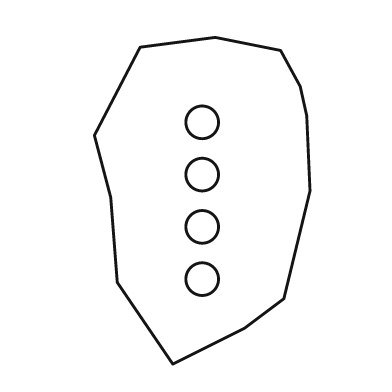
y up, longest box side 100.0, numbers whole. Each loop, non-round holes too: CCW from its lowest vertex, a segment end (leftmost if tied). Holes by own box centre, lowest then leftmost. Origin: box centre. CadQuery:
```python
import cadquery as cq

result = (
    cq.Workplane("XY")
    .moveTo(-9.0, -50.0)
    .lineTo(13.0, -39.0)
    .lineTo(25.0, -30.0)
    .lineTo(33.0, 3.0)
    .lineTo(32.0, 26.0)
    .lineTo(30.0, 35.0)
    .lineTo(24.0, 46.0)
    .lineTo(4.0, 50.0)
    .lineTo(-19.0, 47.0)
    .lineTo(-33.0, 20.0)
    .lineTo(-28.0, 1.0)
    .lineTo(-26.0, -25.0)
    .close()
    .moveTo(0.0, -24.0)
    .circle(5.0)
    .moveTo(0.0, -8.0)
    .circle(5.0)
    .moveTo(0.0, 8.0)
    .circle(5.0)
    .moveTo(0.0, 24.0)
    .circle(5.0)
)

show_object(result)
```